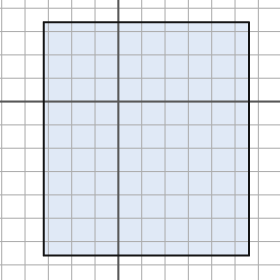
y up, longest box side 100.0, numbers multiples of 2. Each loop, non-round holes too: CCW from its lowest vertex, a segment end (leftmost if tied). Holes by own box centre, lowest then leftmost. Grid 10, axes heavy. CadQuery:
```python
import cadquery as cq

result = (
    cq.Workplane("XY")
    .moveTo(-32.0, -66.0)
    .lineTo(56.0, -66.0)
    .lineTo(56.0, 34.0)
    .lineTo(-32.0, 34.0)
    .close()
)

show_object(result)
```